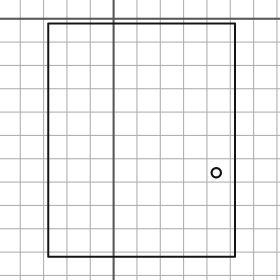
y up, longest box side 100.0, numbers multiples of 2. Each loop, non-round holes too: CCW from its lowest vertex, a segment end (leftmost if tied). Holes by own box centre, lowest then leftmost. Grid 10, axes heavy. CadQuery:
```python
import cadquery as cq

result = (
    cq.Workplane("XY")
    .moveTo(-28.0, -102.0)
    .lineTo(52.0, -102.0)
    .lineTo(52.0, -2.0)
    .lineTo(-28.0, -2.0)
    .close()
    .moveTo(44.0, -66.0)
    .circle(2.0)
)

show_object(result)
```